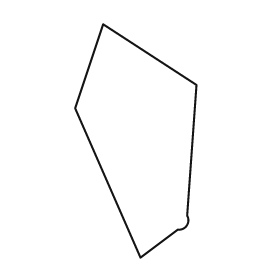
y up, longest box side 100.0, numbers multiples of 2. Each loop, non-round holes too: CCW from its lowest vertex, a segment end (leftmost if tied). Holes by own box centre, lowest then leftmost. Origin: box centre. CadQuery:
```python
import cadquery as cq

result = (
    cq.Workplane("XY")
    .moveTo(2.0, -50.0)
    .lineTo(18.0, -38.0)
    .threePointArc((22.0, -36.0), (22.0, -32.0))
    .lineTo(26.0, 24.0)
    .lineTo(-14.0, 50.0)
    .lineTo(-26.0, 14.0)
    .close()
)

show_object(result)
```